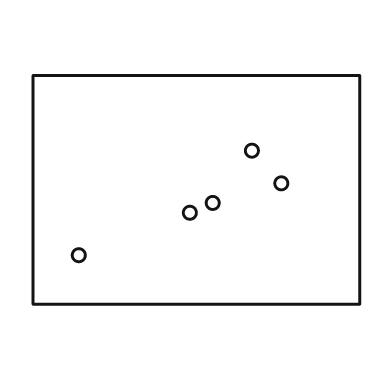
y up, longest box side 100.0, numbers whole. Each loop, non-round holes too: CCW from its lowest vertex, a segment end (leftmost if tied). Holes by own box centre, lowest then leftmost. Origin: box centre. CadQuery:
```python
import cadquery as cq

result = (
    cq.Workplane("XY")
    .moveTo(-50.0, -35.0)
    .lineTo(50.0, -35.0)
    .lineTo(50.0, 35.0)
    .lineTo(-50.0, 35.0)
    .close()
    .moveTo(-36.0, -20.0)
    .circle(2.0)
    .moveTo(-2.0, -7.0)
    .circle(2.0)
    .moveTo(5.0, -4.0)
    .circle(2.0)
    .moveTo(26.0, 2.0)
    .circle(2.0)
    .moveTo(17.0, 12.0)
    .circle(2.0)
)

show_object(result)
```